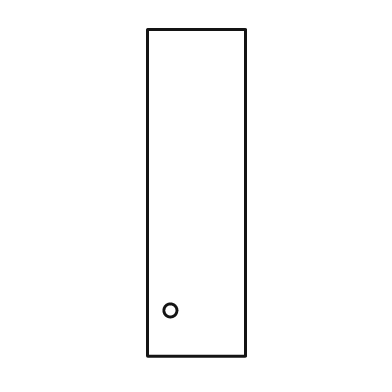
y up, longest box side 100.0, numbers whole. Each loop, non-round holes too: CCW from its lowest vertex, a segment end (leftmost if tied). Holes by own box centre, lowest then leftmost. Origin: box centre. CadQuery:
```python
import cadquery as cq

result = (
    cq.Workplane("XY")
    .moveTo(-15.0, -50.0)
    .lineTo(15.0, -50.0)
    .lineTo(15.0, 50.0)
    .lineTo(-15.0, 50.0)
    .close()
    .moveTo(-8.0, -36.0)
    .circle(2.0)
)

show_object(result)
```